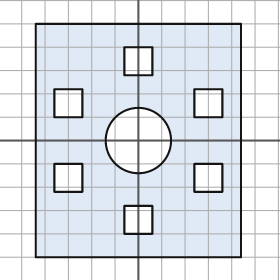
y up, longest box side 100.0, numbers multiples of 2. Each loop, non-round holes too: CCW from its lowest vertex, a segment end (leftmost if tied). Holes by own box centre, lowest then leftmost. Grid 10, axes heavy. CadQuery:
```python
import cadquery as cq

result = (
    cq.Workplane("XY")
    .moveTo(-44.0, -50.0)
    .lineTo(44.0, -50.0)
    .lineTo(44.0, 50.0)
    .lineTo(-44.0, 50.0)
    .close()
    .moveTo(-6.0, -40.0)
    .lineTo(6.0, -40.0)
    .lineTo(6.0, -28.0)
    .lineTo(-6.0, -28.0)
    .close()
    .moveTo(-36.0, -22.0)
    .lineTo(-24.0, -22.0)
    .lineTo(-24.0, -10.0)
    .lineTo(-36.0, -10.0)
    .close()
    .moveTo(24.0, -22.0)
    .lineTo(36.0, -22.0)
    .lineTo(36.0, -10.0)
    .lineTo(24.0, -10.0)
    .close()
    .moveTo(0.0, 0.0)
    .circle(14.0)
    .moveTo(-36.0, 10.0)
    .lineTo(-24.0, 10.0)
    .lineTo(-24.0, 22.0)
    .lineTo(-36.0, 22.0)
    .close()
    .moveTo(24.0, 10.0)
    .lineTo(36.0, 10.0)
    .lineTo(36.0, 22.0)
    .lineTo(24.0, 22.0)
    .close()
    .moveTo(-6.0, 28.0)
    .lineTo(6.0, 28.0)
    .lineTo(6.0, 40.0)
    .lineTo(-6.0, 40.0)
    .close()
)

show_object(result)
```